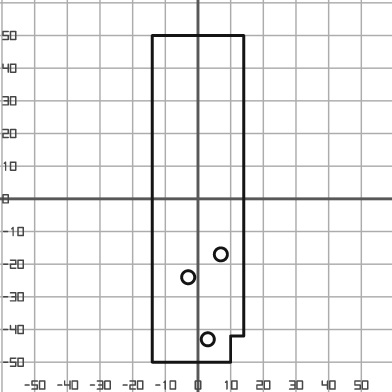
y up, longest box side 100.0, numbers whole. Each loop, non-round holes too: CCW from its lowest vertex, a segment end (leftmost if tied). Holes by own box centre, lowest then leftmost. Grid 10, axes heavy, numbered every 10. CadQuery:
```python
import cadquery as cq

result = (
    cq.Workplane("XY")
    .moveTo(-14.0, -50.0)
    .lineTo(10.0, -50.0)
    .lineTo(10.0, -42.0)
    .lineTo(14.0, -42.0)
    .lineTo(14.0, 50.0)
    .lineTo(-14.0, 50.0)
    .close()
    .moveTo(3.0, -43.0)
    .circle(2.0)
    .moveTo(-3.0, -24.0)
    .circle(2.0)
    .moveTo(7.0, -17.0)
    .circle(2.0)
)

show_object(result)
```